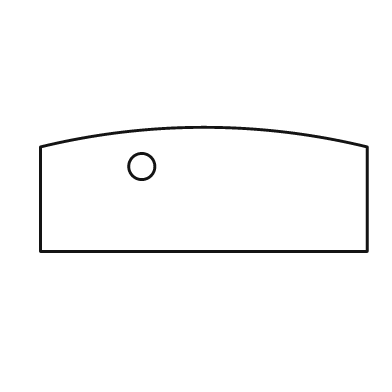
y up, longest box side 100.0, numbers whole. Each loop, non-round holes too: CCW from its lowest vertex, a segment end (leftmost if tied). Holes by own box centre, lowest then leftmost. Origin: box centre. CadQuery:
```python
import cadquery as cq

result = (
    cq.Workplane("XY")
    .moveTo(-50.0, -19.0)
    .lineTo(50.0, -19.0)
    .lineTo(50.0, 13.0)
    .threePointArc((0.0, 19.0), (-50.0, 13.0))
    .close()
    .moveTo(-19.0, 7.0)
    .circle(4.0)
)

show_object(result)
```